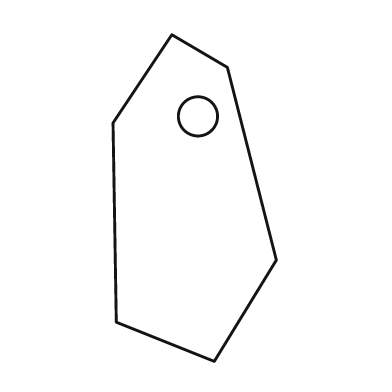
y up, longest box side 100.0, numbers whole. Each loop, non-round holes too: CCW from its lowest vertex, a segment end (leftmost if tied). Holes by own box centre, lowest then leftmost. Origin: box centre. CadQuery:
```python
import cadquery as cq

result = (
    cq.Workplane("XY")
    .moveTo(6.0, -50.0)
    .lineTo(25.0, -19.0)
    .lineTo(10.0, 40.0)
    .lineTo(-7.0, 50.0)
    .lineTo(-25.0, 23.0)
    .lineTo(-24.0, -38.0)
    .close()
    .moveTo(1.0, 25.0)
    .circle(6.0)
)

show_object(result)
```